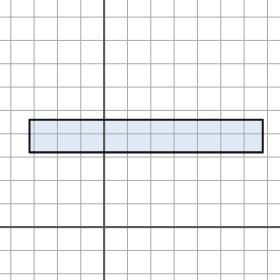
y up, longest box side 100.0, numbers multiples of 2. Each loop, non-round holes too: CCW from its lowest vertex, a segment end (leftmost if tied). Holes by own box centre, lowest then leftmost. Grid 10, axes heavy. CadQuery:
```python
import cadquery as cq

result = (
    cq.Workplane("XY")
    .moveTo(-32.0, 32.0)
    .lineTo(68.0, 32.0)
    .lineTo(68.0, 46.0)
    .lineTo(-32.0, 46.0)
    .close()
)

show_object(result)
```